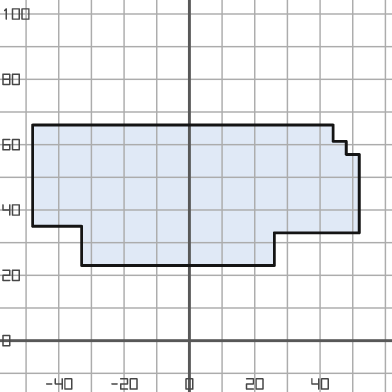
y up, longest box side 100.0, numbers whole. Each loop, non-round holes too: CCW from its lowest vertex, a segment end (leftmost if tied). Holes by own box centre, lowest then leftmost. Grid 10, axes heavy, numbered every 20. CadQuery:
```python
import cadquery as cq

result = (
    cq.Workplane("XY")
    .moveTo(-33.0, 23.0)
    .lineTo(26.0, 23.0)
    .lineTo(26.0, 33.0)
    .lineTo(52.0, 33.0)
    .lineTo(52.0, 57.0)
    .lineTo(48.0, 57.0)
    .lineTo(48.0, 61.0)
    .lineTo(44.0, 61.0)
    .lineTo(44.0, 66.0)
    .lineTo(-48.0, 66.0)
    .lineTo(-48.0, 35.0)
    .lineTo(-33.0, 35.0)
    .close()
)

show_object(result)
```